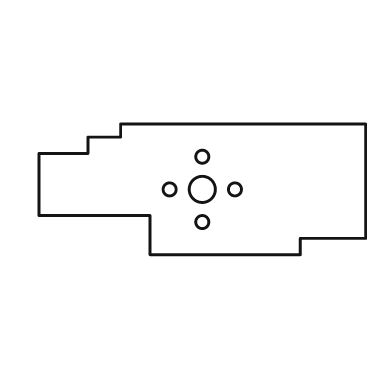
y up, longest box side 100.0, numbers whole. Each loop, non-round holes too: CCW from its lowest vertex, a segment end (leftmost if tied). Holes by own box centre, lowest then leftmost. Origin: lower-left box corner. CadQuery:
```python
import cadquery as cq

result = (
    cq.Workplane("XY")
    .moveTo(34.0, 0.0)
    .lineTo(80.0, 0.0)
    .lineTo(80.0, 5.0)
    .lineTo(100.0, 5.0)
    .lineTo(100.0, 40.0)
    .lineTo(25.0, 40.0)
    .lineTo(25.0, 36.0)
    .lineTo(15.0, 36.0)
    .lineTo(15.0, 31.0)
    .lineTo(0.0, 31.0)
    .lineTo(0.0, 12.0)
    .lineTo(34.0, 12.0)
    .close()
    .moveTo(50.0, 10.0)
    .circle(2.0)
    .moveTo(40.0, 20.0)
    .circle(2.0)
    .moveTo(50.0, 20.0)
    .circle(4.0)
    .moveTo(60.0, 20.0)
    .circle(2.0)
    .moveTo(50.0, 30.0)
    .circle(2.0)
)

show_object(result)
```